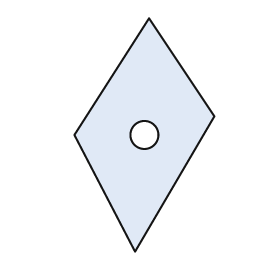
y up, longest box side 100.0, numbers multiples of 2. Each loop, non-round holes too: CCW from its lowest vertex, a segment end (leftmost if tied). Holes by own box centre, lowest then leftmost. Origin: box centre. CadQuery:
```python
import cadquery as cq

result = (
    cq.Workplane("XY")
    .moveTo(-4.0, -50.0)
    .lineTo(30.0, 8.0)
    .lineTo(2.0, 50.0)
    .lineTo(-30.0, 0.0)
    .close()
    .moveTo(0.0, 0.0)
    .circle(6.0)
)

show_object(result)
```